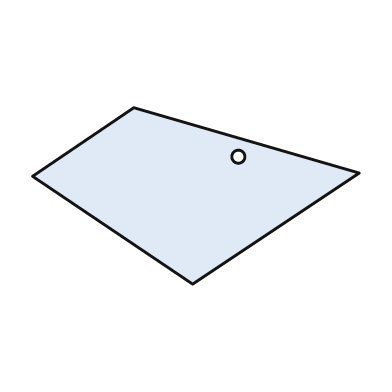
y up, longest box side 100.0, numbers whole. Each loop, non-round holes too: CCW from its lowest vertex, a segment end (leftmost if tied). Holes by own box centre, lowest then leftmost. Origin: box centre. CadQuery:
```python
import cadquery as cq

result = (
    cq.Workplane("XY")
    .moveTo(-1.0, -27.0)
    .lineTo(50.0, 7.0)
    .lineTo(-19.0, 27.0)
    .lineTo(-50.0, 6.0)
    .close()
    .moveTo(13.0, 12.0)
    .circle(2.0)
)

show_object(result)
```